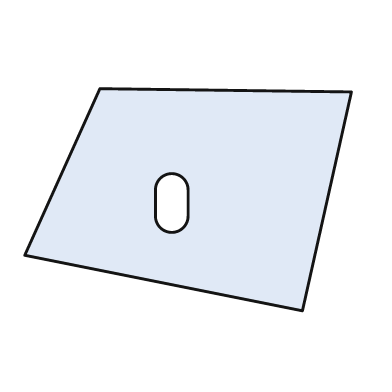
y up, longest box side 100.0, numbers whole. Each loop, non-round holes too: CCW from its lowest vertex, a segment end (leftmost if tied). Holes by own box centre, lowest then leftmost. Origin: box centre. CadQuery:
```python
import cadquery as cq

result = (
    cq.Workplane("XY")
    .moveTo(35.0, -34.0)
    .lineTo(50.0, 33.0)
    .lineTo(-27.0, 34.0)
    .lineTo(-50.0, -17.0)
    .close()
    .moveTo(-10.0, -5.0)
    .threePointArc((-5.0, -10.0), (0.0, -5.0))
    .lineTo(0.0, 3.0)
    .threePointArc((-5.0, 8.0), (-10.0, 3.0))
    .close()
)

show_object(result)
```